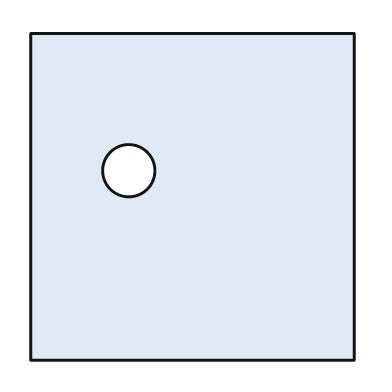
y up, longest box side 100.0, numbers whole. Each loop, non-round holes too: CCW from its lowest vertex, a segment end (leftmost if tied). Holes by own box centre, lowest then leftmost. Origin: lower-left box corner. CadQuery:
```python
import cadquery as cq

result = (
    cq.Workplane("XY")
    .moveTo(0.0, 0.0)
    .lineTo(99.0, 0.0)
    .lineTo(99.0, 100.0)
    .lineTo(0.0, 100.0)
    .close()
    .moveTo(30.0, 58.0)
    .circle(8.0)
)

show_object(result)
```